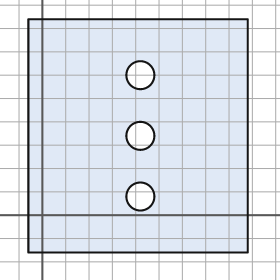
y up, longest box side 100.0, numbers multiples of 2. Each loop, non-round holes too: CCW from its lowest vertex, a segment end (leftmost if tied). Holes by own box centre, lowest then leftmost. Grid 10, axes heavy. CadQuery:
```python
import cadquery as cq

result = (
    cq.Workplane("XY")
    .moveTo(-6.0, -16.0)
    .lineTo(88.0, -16.0)
    .lineTo(88.0, 84.0)
    .lineTo(-6.0, 84.0)
    .close()
    .moveTo(42.0, 8.0)
    .circle(6.0)
    .moveTo(42.0, 34.0)
    .circle(6.0)
    .moveTo(42.0, 60.0)
    .circle(6.0)
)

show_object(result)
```